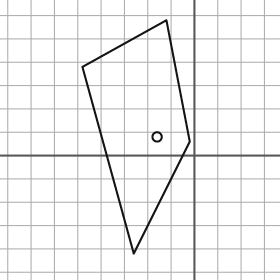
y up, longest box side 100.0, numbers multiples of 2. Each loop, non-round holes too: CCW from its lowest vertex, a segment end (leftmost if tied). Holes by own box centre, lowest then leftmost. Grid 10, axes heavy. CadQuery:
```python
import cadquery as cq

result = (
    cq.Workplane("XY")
    .moveTo(-26.0, -42.0)
    .lineTo(-2.0, 6.0)
    .lineTo(-12.0, 58.0)
    .lineTo(-48.0, 38.0)
    .close()
    .moveTo(-16.0, 8.0)
    .circle(2.0)
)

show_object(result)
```